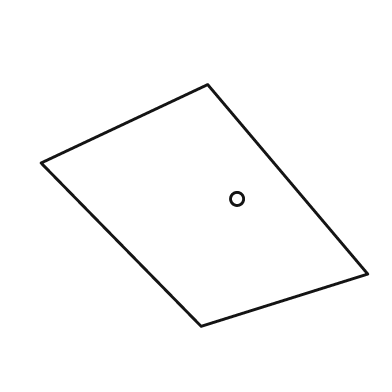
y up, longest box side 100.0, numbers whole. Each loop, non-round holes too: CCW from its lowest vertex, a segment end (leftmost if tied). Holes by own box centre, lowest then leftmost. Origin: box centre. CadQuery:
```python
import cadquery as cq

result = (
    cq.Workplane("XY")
    .moveTo(-1.0, -37.0)
    .lineTo(50.0, -21.0)
    .lineTo(1.0, 37.0)
    .lineTo(-50.0, 13.0)
    .close()
    .moveTo(10.0, 2.0)
    .circle(2.0)
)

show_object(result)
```